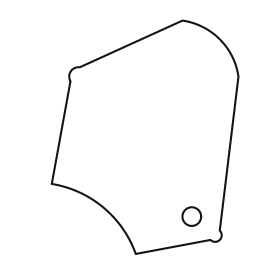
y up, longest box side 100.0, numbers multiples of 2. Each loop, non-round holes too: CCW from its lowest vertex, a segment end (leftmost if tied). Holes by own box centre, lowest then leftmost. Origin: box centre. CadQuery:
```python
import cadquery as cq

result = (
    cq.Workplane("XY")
    .moveTo(-4.0, -50.0)
    .lineTo(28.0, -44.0)
    .threePointArc((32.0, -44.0), (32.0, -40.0))
    .lineTo(40.0, 26.0)
    .threePointArc((32.0, 42.0), (16.0, 50.0))
    .lineTo(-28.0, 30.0)
    .threePointArc((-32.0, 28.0), (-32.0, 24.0))
    .lineTo(-40.0, -20.0)
    .threePointArc((-18.0, -30.0), (-4.0, -50.0))
    .close()
    .moveTo(20.0, -34.0)
    .circle(4.0)
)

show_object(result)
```